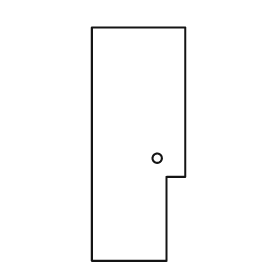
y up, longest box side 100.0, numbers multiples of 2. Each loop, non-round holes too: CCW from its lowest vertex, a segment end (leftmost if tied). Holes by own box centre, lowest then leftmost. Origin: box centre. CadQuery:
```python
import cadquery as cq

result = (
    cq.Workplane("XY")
    .moveTo(-20.0, -50.0)
    .lineTo(12.0, -50.0)
    .lineTo(12.0, -14.0)
    .lineTo(20.0, -14.0)
    .lineTo(20.0, 50.0)
    .lineTo(-20.0, 50.0)
    .close()
    .moveTo(8.0, -6.0)
    .circle(2.0)
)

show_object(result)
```